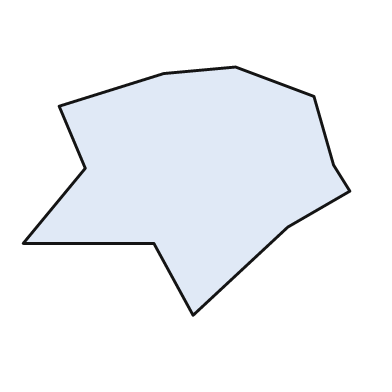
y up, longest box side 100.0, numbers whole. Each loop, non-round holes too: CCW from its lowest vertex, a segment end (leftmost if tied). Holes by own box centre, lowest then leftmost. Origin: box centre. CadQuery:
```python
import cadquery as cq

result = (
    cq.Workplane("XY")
    .moveTo(2.0, -38.0)
    .lineTo(31.0, -11.0)
    .lineTo(50.0, 0.0)
    .lineTo(45.0, 8.0)
    .lineTo(39.0, 29.0)
    .lineTo(15.0, 38.0)
    .lineTo(-7.0, 36.0)
    .lineTo(-39.0, 26.0)
    .lineTo(-31.0, 7.0)
    .lineTo(-50.0, -16.0)
    .lineTo(-10.0, -16.0)
    .close()
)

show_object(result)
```